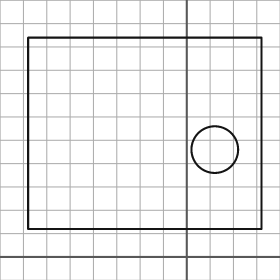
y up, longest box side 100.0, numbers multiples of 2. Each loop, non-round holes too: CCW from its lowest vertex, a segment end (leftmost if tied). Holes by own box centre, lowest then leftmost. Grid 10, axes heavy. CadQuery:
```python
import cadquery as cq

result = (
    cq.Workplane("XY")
    .moveTo(-68.0, 12.0)
    .lineTo(32.0, 12.0)
    .lineTo(32.0, 94.0)
    .lineTo(-68.0, 94.0)
    .close()
    .moveTo(12.0, 46.0)
    .circle(10.0)
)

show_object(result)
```